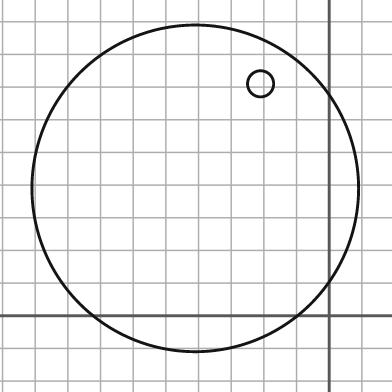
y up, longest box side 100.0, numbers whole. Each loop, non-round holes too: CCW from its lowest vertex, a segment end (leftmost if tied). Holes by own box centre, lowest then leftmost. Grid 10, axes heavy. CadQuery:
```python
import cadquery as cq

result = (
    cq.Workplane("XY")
    .moveTo(-41.0, 39.0)
    .circle(50.0)
    .moveTo(-21.0, 71.0)
    .circle(4.0)
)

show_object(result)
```